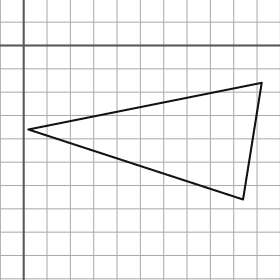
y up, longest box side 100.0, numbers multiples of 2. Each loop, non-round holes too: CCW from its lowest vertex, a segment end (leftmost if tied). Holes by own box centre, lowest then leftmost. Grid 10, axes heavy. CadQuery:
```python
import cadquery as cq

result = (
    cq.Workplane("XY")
    .moveTo(94.0, -66.0)
    .lineTo(102.0, -16.0)
    .lineTo(2.0, -36.0)
    .close()
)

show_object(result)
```